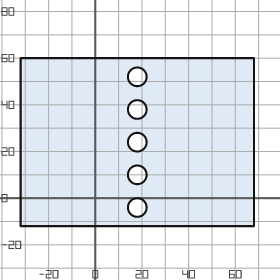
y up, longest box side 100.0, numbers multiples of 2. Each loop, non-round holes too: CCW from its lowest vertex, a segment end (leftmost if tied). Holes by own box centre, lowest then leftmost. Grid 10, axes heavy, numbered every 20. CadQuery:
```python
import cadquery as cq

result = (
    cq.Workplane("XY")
    .moveTo(-32.0, -12.0)
    .lineTo(68.0, -12.0)
    .lineTo(68.0, 60.0)
    .lineTo(-32.0, 60.0)
    .close()
    .moveTo(18.0, -4.0)
    .circle(4.0)
    .moveTo(18.0, 10.0)
    .circle(4.0)
    .moveTo(18.0, 24.0)
    .circle(4.0)
    .moveTo(18.0, 38.0)
    .circle(4.0)
    .moveTo(18.0, 52.0)
    .circle(4.0)
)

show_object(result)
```